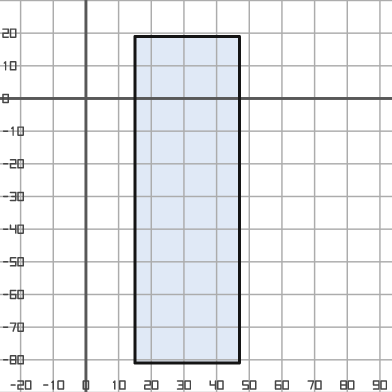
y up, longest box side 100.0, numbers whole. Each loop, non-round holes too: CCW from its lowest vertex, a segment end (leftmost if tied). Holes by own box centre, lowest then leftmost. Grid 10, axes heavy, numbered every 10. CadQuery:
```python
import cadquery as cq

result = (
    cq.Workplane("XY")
    .moveTo(15.0, -81.0)
    .lineTo(47.0, -81.0)
    .lineTo(47.0, 19.0)
    .lineTo(15.0, 19.0)
    .close()
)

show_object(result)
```